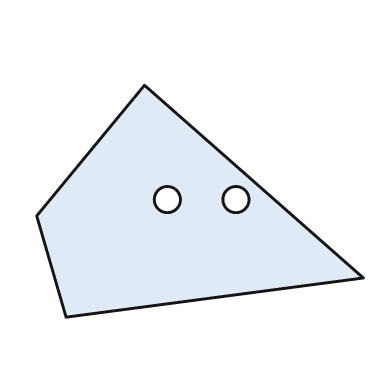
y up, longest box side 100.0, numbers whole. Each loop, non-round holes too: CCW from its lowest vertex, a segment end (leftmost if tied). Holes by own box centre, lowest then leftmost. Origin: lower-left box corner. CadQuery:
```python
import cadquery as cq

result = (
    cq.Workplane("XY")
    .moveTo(9.0, 0.0)
    .lineTo(100.0, 12.0)
    .lineTo(33.0, 71.0)
    .lineTo(0.0, 31.0)
    .close()
    .moveTo(40.0, 36.0)
    .circle(4.0)
    .moveTo(61.0, 36.0)
    .circle(4.0)
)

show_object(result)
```